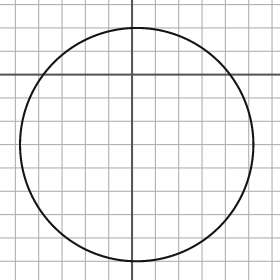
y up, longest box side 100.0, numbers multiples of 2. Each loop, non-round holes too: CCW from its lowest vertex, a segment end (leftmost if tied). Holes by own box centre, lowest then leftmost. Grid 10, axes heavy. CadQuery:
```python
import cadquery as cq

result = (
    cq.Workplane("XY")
    .moveTo(2.0, -30.0)
    .circle(50.0)
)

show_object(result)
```